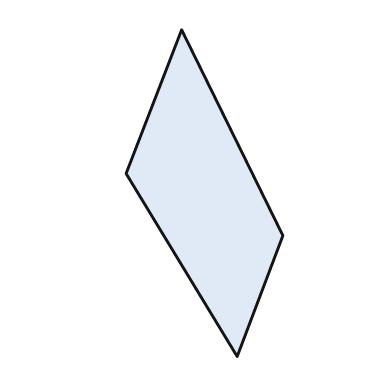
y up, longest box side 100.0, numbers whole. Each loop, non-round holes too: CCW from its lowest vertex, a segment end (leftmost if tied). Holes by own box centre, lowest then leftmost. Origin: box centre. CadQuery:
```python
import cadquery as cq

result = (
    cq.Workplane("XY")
    .moveTo(10.0, -50.0)
    .lineTo(24.0, -13.0)
    .lineTo(-7.0, 50.0)
    .lineTo(-24.0, 6.0)
    .close()
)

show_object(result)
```